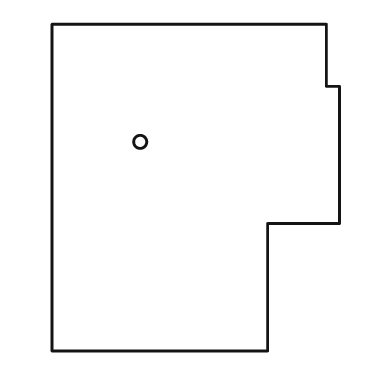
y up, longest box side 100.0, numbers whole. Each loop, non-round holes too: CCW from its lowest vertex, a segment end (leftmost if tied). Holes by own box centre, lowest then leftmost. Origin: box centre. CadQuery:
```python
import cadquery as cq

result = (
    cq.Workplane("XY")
    .moveTo(-44.0, -50.0)
    .lineTo(22.0, -50.0)
    .lineTo(22.0, -11.0)
    .lineTo(44.0, -11.0)
    .lineTo(44.0, 31.0)
    .lineTo(40.0, 31.0)
    .lineTo(40.0, 50.0)
    .lineTo(-44.0, 50.0)
    .close()
    .moveTo(-17.0, 14.0)
    .circle(2.0)
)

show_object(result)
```